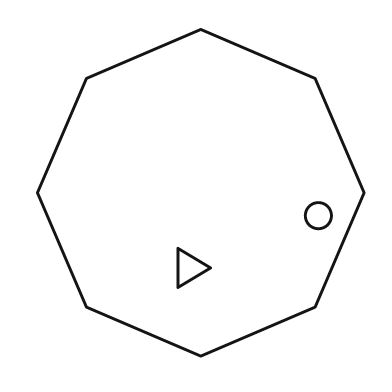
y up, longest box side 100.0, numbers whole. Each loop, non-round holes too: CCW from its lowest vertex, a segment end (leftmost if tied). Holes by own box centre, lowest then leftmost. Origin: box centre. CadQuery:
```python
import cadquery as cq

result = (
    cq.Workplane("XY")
    .moveTo(0.0, -50.0)
    .lineTo(35.0, -35.0)
    .lineTo(50.0, 0.0)
    .lineTo(35.0, 35.0)
    .lineTo(0.0, 50.0)
    .lineTo(-35.0, 35.0)
    .lineTo(-50.0, 0.0)
    .lineTo(-35.0, -35.0)
    .close()
    .moveTo(-7.0, -29.0)
    .lineTo(3.0, -23.0)
    .lineTo(-7.0, -17.0)
    .close()
    .moveTo(36.0, -7.0)
    .circle(4.0)
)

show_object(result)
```